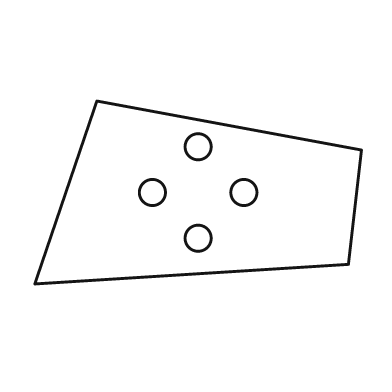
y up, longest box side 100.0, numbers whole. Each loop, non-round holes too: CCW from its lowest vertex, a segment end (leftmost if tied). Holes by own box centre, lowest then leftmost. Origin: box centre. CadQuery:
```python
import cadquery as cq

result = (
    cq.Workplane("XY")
    .moveTo(-50.0, -28.0)
    .lineTo(46.0, -22.0)
    .lineTo(50.0, 13.0)
    .lineTo(-31.0, 28.0)
    .close()
    .moveTo(0.0, -14.0)
    .circle(4.0)
    .moveTo(-14.0, 0.0)
    .circle(4.0)
    .moveTo(14.0, 0.0)
    .circle(4.0)
    .moveTo(0.0, 14.0)
    .circle(4.0)
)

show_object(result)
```